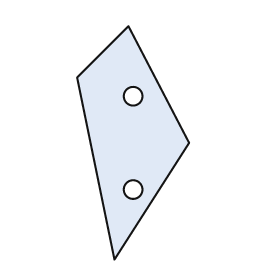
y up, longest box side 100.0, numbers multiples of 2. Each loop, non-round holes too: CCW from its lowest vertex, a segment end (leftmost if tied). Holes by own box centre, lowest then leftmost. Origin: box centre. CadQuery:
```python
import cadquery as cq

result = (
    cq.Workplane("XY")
    .moveTo(-8.0, -50.0)
    .lineTo(24.0, 0.0)
    .lineTo(-2.0, 50.0)
    .lineTo(-24.0, 28.0)
    .close()
    .moveTo(0.0, -20.0)
    .circle(4.0)
    .moveTo(0.0, 20.0)
    .circle(4.0)
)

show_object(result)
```